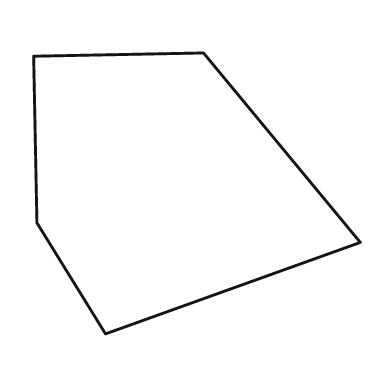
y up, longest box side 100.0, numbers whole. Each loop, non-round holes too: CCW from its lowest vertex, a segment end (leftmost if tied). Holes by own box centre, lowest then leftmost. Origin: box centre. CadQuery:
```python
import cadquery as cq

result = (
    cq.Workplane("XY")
    .moveTo(-28.0, -43.0)
    .lineTo(50.0, -15.0)
    .lineTo(2.0, 43.0)
    .lineTo(-50.0, 42.0)
    .lineTo(-49.0, -9.0)
    .close()
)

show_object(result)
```